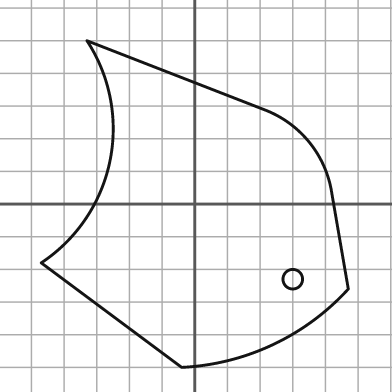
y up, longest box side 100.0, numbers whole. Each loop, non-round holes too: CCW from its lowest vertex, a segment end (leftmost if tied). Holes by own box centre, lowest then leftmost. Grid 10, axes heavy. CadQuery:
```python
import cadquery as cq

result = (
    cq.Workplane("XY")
    .moveTo(-4.0, -50.0)
    .threePointArc((24.0, -43.0), (47.0, -26.0))
    .lineTo(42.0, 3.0)
    .threePointArc((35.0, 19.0), (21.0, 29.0))
    .lineTo(-33.0, 50.0)
    .threePointArc((-26.0, 13.0), (-47.0, -18.0))
    .close()
    .moveTo(30.0, -23.0)
    .circle(3.0)
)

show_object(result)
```